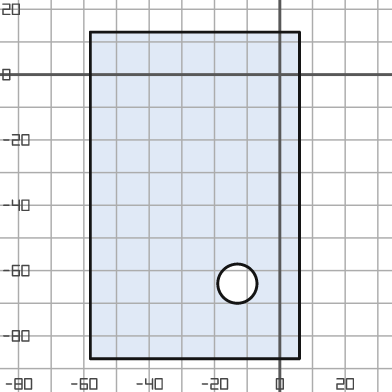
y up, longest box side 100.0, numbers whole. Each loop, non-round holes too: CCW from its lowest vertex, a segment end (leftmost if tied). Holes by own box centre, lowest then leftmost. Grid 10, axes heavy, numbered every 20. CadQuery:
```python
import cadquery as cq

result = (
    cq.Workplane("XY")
    .moveTo(-58.0, -87.0)
    .lineTo(6.0, -87.0)
    .lineTo(6.0, 13.0)
    .lineTo(-58.0, 13.0)
    .close()
    .moveTo(-13.0, -64.0)
    .circle(6.0)
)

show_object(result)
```